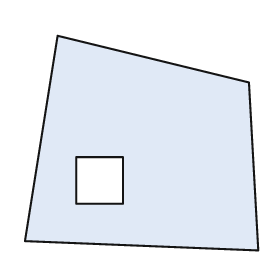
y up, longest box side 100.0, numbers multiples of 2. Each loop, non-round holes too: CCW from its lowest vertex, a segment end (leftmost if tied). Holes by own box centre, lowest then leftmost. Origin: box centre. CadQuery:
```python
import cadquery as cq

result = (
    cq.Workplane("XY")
    .moveTo(50.0, -46.0)
    .lineTo(46.0, 26.0)
    .lineTo(-36.0, 46.0)
    .lineTo(-50.0, -42.0)
    .close()
    .moveTo(-28.0, -26.0)
    .lineTo(-8.0, -26.0)
    .lineTo(-8.0, -6.0)
    .lineTo(-28.0, -6.0)
    .close()
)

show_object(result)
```